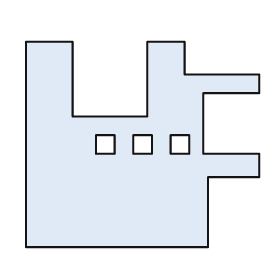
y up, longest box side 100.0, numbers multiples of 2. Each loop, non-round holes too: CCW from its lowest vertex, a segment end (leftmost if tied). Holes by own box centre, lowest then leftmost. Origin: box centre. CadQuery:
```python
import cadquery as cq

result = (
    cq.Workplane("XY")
    .moveTo(-50.0, -44.0)
    .lineTo(28.0, -44.0)
    .lineTo(28.0, -14.0)
    .lineTo(50.0, -14.0)
    .lineTo(50.0, -4.0)
    .lineTo(26.0, -4.0)
    .lineTo(26.0, 22.0)
    .lineTo(50.0, 22.0)
    .lineTo(50.0, 30.0)
    .lineTo(18.0, 30.0)
    .lineTo(18.0, 44.0)
    .lineTo(2.0, 44.0)
    .lineTo(2.0, 12.0)
    .lineTo(-30.0, 12.0)
    .lineTo(-30.0, 44.0)
    .lineTo(-50.0, 44.0)
    .close()
    .moveTo(-20.0, -4.0)
    .lineTo(-12.0, -4.0)
    .lineTo(-12.0, 4.0)
    .lineTo(-20.0, 4.0)
    .close()
    .moveTo(-4.0, -4.0)
    .lineTo(4.0, -4.0)
    .lineTo(4.0, 4.0)
    .lineTo(-4.0, 4.0)
    .close()
    .moveTo(12.0, -4.0)
    .lineTo(20.0, -4.0)
    .lineTo(20.0, 4.0)
    .lineTo(12.0, 4.0)
    .close()
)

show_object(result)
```